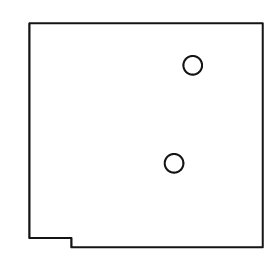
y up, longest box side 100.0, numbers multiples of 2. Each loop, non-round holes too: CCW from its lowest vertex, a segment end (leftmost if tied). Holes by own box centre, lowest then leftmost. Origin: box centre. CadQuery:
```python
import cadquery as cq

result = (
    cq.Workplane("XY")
    .moveTo(-32.0, -48.0)
    .lineTo(50.0, -48.0)
    .lineTo(50.0, 48.0)
    .lineTo(-50.0, 48.0)
    .lineTo(-50.0, -44.0)
    .lineTo(-32.0, -44.0)
    .close()
    .moveTo(12.0, -12.0)
    .circle(4.0)
    .moveTo(20.0, 30.0)
    .circle(4.0)
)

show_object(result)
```